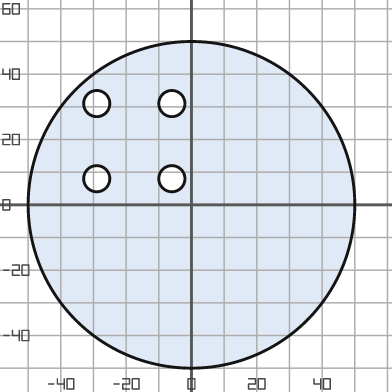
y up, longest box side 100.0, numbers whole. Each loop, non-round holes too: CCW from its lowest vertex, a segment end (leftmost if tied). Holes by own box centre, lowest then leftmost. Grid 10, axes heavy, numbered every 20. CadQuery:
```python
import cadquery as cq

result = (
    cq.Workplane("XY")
    .moveTo(0.0, 0.0)
    .circle(50.0)
    .moveTo(-29.0, 8.0)
    .circle(4.0)
    .moveTo(-6.0, 8.0)
    .circle(4.0)
    .moveTo(-29.0, 31.0)
    .circle(4.0)
    .moveTo(-6.0, 31.0)
    .circle(4.0)
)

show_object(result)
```